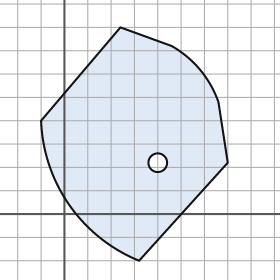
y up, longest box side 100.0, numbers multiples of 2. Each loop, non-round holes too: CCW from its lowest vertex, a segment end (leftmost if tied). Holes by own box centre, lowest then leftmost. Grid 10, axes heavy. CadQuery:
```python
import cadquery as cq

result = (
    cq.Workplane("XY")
    .moveTo(32.0, -20.0)
    .lineTo(70.0, 22.0)
    .lineTo(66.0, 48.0)
    .threePointArc((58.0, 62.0), (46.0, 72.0))
    .lineTo(24.0, 80.0)
    .lineTo(-10.0, 40.0)
    .threePointArc((2.0, 4.0), (32.0, -20.0))
    .close()
    .moveTo(40.0, 22.0)
    .circle(4.0)
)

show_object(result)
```